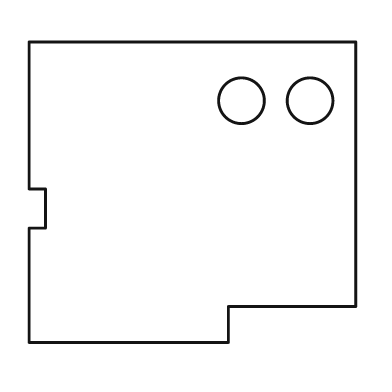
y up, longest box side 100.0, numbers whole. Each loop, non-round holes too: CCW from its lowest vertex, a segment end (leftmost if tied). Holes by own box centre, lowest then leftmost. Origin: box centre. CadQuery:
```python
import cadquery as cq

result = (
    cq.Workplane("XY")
    .moveTo(-50.0, -46.0)
    .lineTo(11.0, -46.0)
    .lineTo(11.0, -35.0)
    .lineTo(50.0, -35.0)
    .lineTo(50.0, 46.0)
    .lineTo(-50.0, 46.0)
    .lineTo(-50.0, 1.0)
    .lineTo(-45.0, 1.0)
    .lineTo(-45.0, -11.0)
    .lineTo(-50.0, -11.0)
    .close()
    .moveTo(15.0, 28.0)
    .circle(7.0)
    .moveTo(36.0, 28.0)
    .circle(7.0)
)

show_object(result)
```